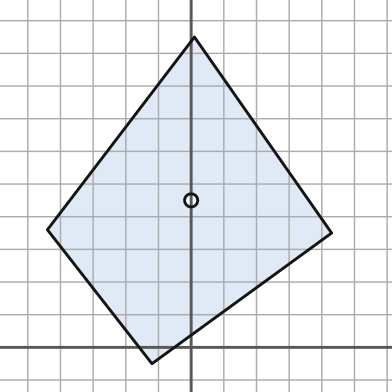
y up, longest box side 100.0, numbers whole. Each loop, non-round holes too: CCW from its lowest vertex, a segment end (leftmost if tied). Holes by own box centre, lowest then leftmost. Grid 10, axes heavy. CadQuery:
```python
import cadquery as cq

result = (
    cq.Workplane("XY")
    .moveTo(-12.0, -5.0)
    .lineTo(43.0, 35.0)
    .lineTo(1.0, 95.0)
    .lineTo(-44.0, 36.0)
    .close()
    .moveTo(0.0, 45.0)
    .circle(2.0)
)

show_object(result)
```